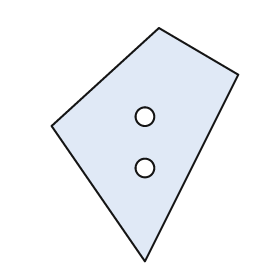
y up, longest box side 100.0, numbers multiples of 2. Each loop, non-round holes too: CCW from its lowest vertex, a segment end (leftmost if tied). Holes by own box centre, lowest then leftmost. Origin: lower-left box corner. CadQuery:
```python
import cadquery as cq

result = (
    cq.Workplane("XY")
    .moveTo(40.0, 0.0)
    .lineTo(80.0, 80.0)
    .lineTo(46.0, 100.0)
    .lineTo(0.0, 58.0)
    .close()
    .moveTo(40.0, 40.0)
    .circle(4.0)
    .moveTo(40.0, 62.0)
    .circle(4.0)
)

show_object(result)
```